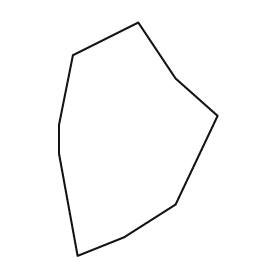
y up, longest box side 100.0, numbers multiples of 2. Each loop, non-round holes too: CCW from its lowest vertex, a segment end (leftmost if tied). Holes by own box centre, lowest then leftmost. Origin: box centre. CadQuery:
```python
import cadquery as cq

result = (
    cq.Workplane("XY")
    .moveTo(-26.0, -50.0)
    .lineTo(-6.0, -42.0)
    .lineTo(16.0, -28.0)
    .lineTo(34.0, 10.0)
    .lineTo(16.0, 26.0)
    .lineTo(0.0, 50.0)
    .lineTo(-28.0, 36.0)
    .lineTo(-34.0, 6.0)
    .lineTo(-34.0, -6.0)
    .close()
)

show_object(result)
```